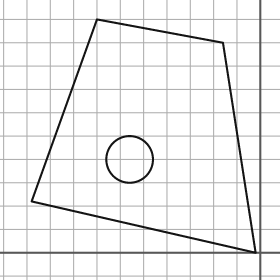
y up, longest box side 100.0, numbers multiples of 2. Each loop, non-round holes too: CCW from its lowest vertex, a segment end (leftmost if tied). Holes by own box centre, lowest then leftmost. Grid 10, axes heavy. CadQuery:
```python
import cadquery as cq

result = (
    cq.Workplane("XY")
    .moveTo(-2.0, 0.0)
    .lineTo(-16.0, 90.0)
    .lineTo(-70.0, 100.0)
    .lineTo(-98.0, 22.0)
    .close()
    .moveTo(-56.0, 40.0)
    .circle(10.0)
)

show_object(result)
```